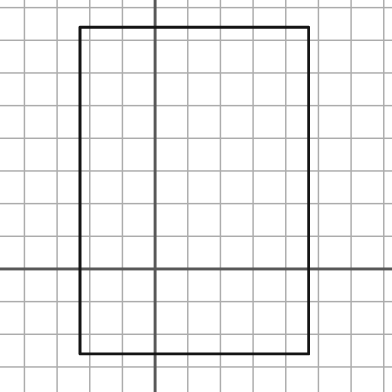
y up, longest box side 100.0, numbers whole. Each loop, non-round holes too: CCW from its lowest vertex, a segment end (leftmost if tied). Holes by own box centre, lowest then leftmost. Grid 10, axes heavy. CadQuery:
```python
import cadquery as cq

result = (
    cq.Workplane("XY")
    .moveTo(-23.0, -26.0)
    .lineTo(47.0, -26.0)
    .lineTo(47.0, 74.0)
    .lineTo(-23.0, 74.0)
    .close()
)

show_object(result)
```